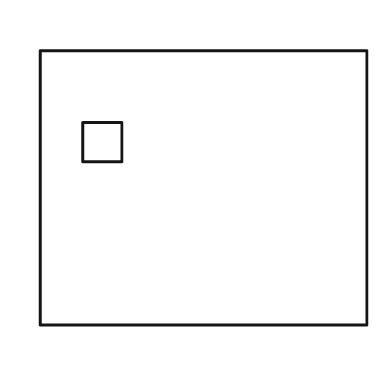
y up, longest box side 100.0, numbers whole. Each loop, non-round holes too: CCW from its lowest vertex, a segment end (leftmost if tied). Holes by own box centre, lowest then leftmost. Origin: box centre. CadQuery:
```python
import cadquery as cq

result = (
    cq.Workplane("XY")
    .moveTo(-50.0, -42.0)
    .lineTo(50.0, -42.0)
    .lineTo(50.0, 42.0)
    .lineTo(-50.0, 42.0)
    .close()
    .moveTo(-37.0, 8.0)
    .lineTo(-25.0, 8.0)
    .lineTo(-25.0, 20.0)
    .lineTo(-37.0, 20.0)
    .close()
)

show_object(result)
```